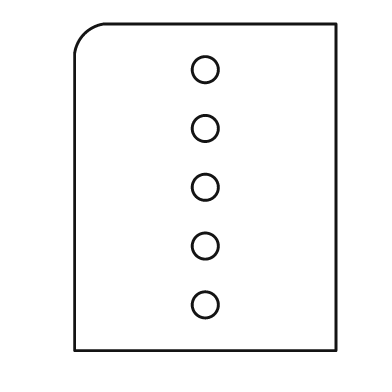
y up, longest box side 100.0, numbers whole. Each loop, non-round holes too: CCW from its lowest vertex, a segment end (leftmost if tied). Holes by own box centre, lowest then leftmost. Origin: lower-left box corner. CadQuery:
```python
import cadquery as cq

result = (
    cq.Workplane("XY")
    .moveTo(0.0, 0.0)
    .lineTo(80.0, 0.0)
    .lineTo(80.0, 100.0)
    .lineTo(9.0, 100.0)
    .threePointArc((3.0, 97.0), (0.0, 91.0))
    .close()
    .moveTo(40.0, 14.0)
    .circle(4.0)
    .moveTo(40.0, 32.0)
    .circle(4.0)
    .moveTo(40.0, 50.0)
    .circle(4.0)
    .moveTo(40.0, 68.0)
    .circle(4.0)
    .moveTo(40.0, 86.0)
    .circle(4.0)
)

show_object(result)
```